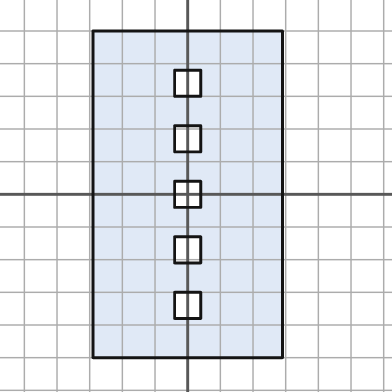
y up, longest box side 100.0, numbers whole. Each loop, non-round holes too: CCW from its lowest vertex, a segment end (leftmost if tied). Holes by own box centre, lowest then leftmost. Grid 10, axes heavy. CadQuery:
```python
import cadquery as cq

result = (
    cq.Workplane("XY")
    .moveTo(-29.0, -50.0)
    .lineTo(29.0, -50.0)
    .lineTo(29.0, 50.0)
    .lineTo(-29.0, 50.0)
    .close()
    .moveTo(-4.0, -38.0)
    .lineTo(4.0, -38.0)
    .lineTo(4.0, -30.0)
    .lineTo(-4.0, -30.0)
    .close()
    .moveTo(-4.0, -21.0)
    .lineTo(4.0, -21.0)
    .lineTo(4.0, -13.0)
    .lineTo(-4.0, -13.0)
    .close()
    .moveTo(-4.0, -4.0)
    .lineTo(4.0, -4.0)
    .lineTo(4.0, 4.0)
    .lineTo(-4.0, 4.0)
    .close()
    .moveTo(-4.0, 13.0)
    .lineTo(4.0, 13.0)
    .lineTo(4.0, 21.0)
    .lineTo(-4.0, 21.0)
    .close()
    .moveTo(-4.0, 30.0)
    .lineTo(4.0, 30.0)
    .lineTo(4.0, 38.0)
    .lineTo(-4.0, 38.0)
    .close()
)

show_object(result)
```